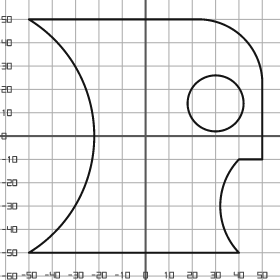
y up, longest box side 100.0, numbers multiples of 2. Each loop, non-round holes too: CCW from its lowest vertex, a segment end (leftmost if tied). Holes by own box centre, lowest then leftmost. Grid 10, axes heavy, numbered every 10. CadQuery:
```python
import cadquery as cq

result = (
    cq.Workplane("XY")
    .moveTo(-50.0, -50.0)
    .lineTo(40.0, -50.0)
    .threePointArc((32.0, -30.0), (40.0, -10.0))
    .lineTo(50.0, -10.0)
    .lineTo(50.0, 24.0)
    .threePointArc((42.0, 42.0), (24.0, 50.0))
    .lineTo(-50.0, 50.0)
    .threePointArc((-22.0, 0.0), (-50.0, -50.0))
    .close()
    .moveTo(30.0, 14.0)
    .circle(12.0)
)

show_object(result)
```